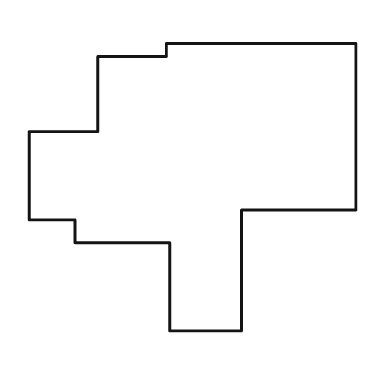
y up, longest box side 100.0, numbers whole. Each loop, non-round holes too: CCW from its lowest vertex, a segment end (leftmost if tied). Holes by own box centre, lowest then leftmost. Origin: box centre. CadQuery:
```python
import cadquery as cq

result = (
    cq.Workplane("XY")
    .moveTo(-7.0, -44.0)
    .lineTo(15.0, -44.0)
    .lineTo(15.0, -7.0)
    .lineTo(50.0, -7.0)
    .lineTo(50.0, 44.0)
    .lineTo(-8.0, 44.0)
    .lineTo(-8.0, 40.0)
    .lineTo(-29.0, 40.0)
    .lineTo(-29.0, 17.0)
    .lineTo(-50.0, 17.0)
    .lineTo(-50.0, -10.0)
    .lineTo(-36.0, -10.0)
    .lineTo(-36.0, -17.0)
    .lineTo(-7.0, -17.0)
    .close()
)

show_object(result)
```